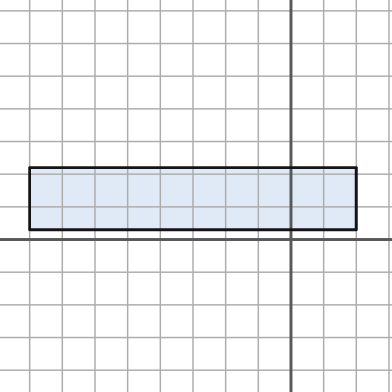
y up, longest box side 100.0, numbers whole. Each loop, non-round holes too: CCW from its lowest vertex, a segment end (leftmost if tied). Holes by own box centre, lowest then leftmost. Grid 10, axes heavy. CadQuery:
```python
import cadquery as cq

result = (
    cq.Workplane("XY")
    .moveTo(-80.0, 3.0)
    .lineTo(20.0, 3.0)
    .lineTo(20.0, 22.0)
    .lineTo(-80.0, 22.0)
    .close()
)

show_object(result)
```